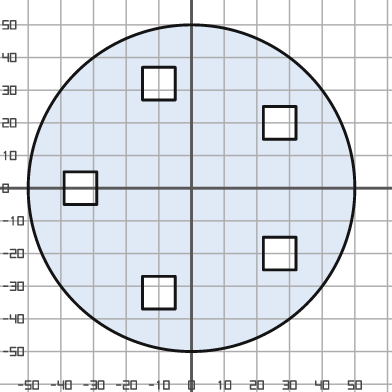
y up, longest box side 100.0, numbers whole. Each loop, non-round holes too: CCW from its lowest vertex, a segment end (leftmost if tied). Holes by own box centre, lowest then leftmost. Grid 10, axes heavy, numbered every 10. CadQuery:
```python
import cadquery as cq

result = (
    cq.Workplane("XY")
    .moveTo(0.0, 0.0)
    .circle(50.0)
    .moveTo(-15.0, -37.0)
    .lineTo(-5.0, -37.0)
    .lineTo(-5.0, -27.0)
    .lineTo(-15.0, -27.0)
    .close()
    .moveTo(22.0, -25.0)
    .lineTo(32.0, -25.0)
    .lineTo(32.0, -15.0)
    .lineTo(22.0, -15.0)
    .close()
    .moveTo(-39.0, -5.0)
    .lineTo(-29.0, -5.0)
    .lineTo(-29.0, 5.0)
    .lineTo(-39.0, 5.0)
    .close()
    .moveTo(22.0, 15.0)
    .lineTo(32.0, 15.0)
    .lineTo(32.0, 25.0)
    .lineTo(22.0, 25.0)
    .close()
    .moveTo(-15.0, 27.0)
    .lineTo(-5.0, 27.0)
    .lineTo(-5.0, 37.0)
    .lineTo(-15.0, 37.0)
    .close()
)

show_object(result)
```